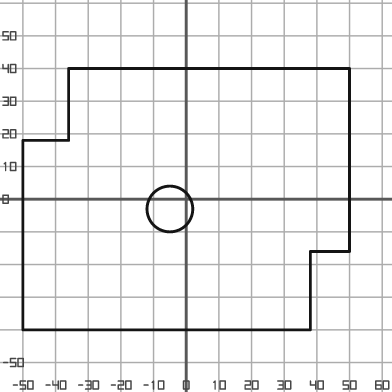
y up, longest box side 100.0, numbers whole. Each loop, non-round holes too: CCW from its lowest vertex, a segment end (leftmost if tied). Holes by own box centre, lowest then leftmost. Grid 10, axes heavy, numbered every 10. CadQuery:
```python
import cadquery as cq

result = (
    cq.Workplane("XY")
    .moveTo(-50.0, -40.0)
    .lineTo(38.0, -40.0)
    .lineTo(38.0, -16.0)
    .lineTo(50.0, -16.0)
    .lineTo(50.0, 40.0)
    .lineTo(-36.0, 40.0)
    .lineTo(-36.0, 18.0)
    .lineTo(-50.0, 18.0)
    .close()
    .moveTo(-5.0, -3.0)
    .circle(7.0)
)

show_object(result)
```